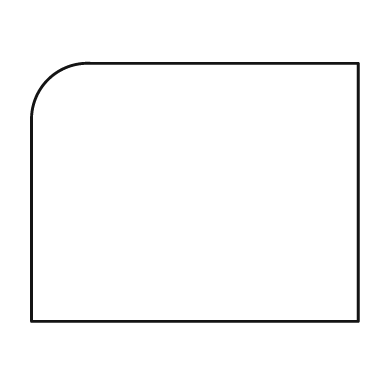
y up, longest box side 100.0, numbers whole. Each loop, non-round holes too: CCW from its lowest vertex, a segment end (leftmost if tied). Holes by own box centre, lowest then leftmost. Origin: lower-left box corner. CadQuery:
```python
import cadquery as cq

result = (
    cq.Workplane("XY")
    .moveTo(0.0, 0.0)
    .lineTo(100.0, 0.0)
    .lineTo(100.0, 79.0)
    .lineTo(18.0, 79.0)
    .threePointArc((5.0, 74.0), (0.0, 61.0))
    .close()
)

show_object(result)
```